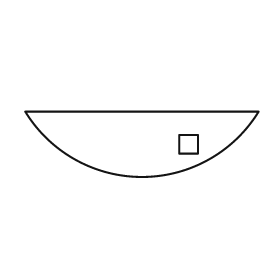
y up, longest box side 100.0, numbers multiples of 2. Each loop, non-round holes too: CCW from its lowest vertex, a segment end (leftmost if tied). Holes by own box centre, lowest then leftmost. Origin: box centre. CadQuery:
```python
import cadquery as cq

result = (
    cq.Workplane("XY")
    .moveTo(-50.0, 14.0)
    .threePointArc((0.0, -14.0), (50.0, 14.0))
    .close()
    .moveTo(16.0, -4.0)
    .lineTo(24.0, -4.0)
    .lineTo(24.0, 4.0)
    .lineTo(16.0, 4.0)
    .close()
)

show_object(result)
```